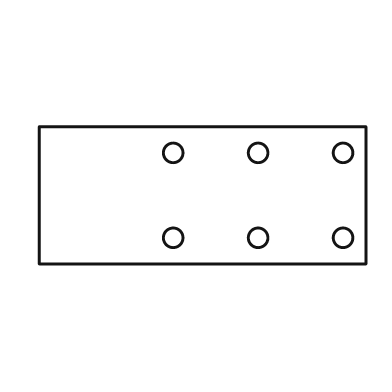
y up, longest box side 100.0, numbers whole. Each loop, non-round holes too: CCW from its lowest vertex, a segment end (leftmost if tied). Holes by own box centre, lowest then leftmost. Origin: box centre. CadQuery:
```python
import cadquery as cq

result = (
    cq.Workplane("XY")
    .moveTo(-50.0, -21.0)
    .lineTo(50.0, -21.0)
    .lineTo(50.0, 21.0)
    .lineTo(-50.0, 21.0)
    .close()
    .moveTo(-9.0, -13.0)
    .circle(3.0)
    .moveTo(17.0, -13.0)
    .circle(3.0)
    .moveTo(43.0, -13.0)
    .circle(3.0)
    .moveTo(-9.0, 13.0)
    .circle(3.0)
    .moveTo(17.0, 13.0)
    .circle(3.0)
    .moveTo(43.0, 13.0)
    .circle(3.0)
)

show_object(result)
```